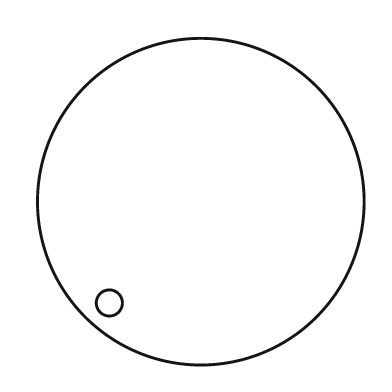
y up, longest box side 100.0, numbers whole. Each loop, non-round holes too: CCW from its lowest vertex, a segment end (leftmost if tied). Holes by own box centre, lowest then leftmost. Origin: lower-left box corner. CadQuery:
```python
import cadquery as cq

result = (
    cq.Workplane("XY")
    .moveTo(50.0, 50.0)
    .circle(50.0)
    .moveTo(22.0, 19.0)
    .circle(4.0)
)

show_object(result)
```